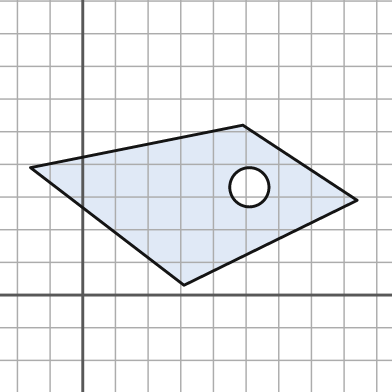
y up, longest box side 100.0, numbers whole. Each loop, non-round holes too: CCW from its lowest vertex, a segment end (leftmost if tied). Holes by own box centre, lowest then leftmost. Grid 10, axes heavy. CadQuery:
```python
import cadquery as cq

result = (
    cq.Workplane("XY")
    .moveTo(31.0, 3.0)
    .lineTo(84.0, 29.0)
    .lineTo(49.0, 52.0)
    .lineTo(-16.0, 39.0)
    .close()
    .moveTo(51.0, 33.0)
    .circle(6.0)
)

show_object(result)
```